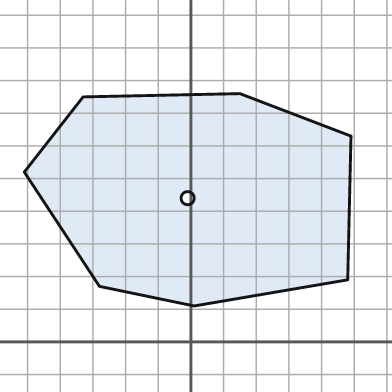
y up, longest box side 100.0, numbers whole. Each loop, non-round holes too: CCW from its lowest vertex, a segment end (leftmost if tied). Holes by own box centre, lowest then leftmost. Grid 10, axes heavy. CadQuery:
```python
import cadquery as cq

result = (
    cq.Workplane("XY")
    .moveTo(1.0, 11.0)
    .lineTo(48.0, 19.0)
    .lineTo(49.0, 63.0)
    .lineTo(15.0, 76.0)
    .lineTo(-33.0, 75.0)
    .lineTo(-51.0, 52.0)
    .lineTo(-28.0, 17.0)
    .close()
    .moveTo(-1.0, 44.0)
    .circle(2.0)
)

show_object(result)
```